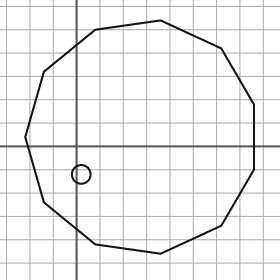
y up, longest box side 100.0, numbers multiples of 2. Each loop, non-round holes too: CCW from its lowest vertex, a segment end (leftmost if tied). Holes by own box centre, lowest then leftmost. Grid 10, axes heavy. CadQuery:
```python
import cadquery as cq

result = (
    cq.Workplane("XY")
    .moveTo(36.0, -46.0)
    .lineTo(62.0, -34.0)
    .lineTo(76.0, -10.0)
    .lineTo(76.0, 18.0)
    .lineTo(62.0, 42.0)
    .lineTo(36.0, 54.0)
    .lineTo(8.0, 50.0)
    .lineTo(-14.0, 32.0)
    .lineTo(-22.0, 4.0)
    .lineTo(-14.0, -24.0)
    .lineTo(8.0, -42.0)
    .close()
    .moveTo(2.0, -12.0)
    .circle(4.0)
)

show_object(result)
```